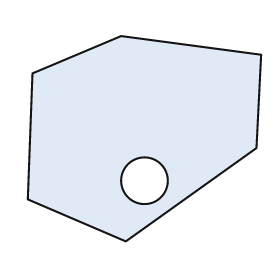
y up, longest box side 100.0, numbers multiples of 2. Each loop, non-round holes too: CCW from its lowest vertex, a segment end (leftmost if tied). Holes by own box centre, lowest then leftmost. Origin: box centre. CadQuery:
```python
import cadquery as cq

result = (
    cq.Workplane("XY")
    .moveTo(-8.0, -44.0)
    .lineTo(48.0, -4.0)
    .lineTo(50.0, 36.0)
    .lineTo(-10.0, 44.0)
    .lineTo(-48.0, 28.0)
    .lineTo(-50.0, -26.0)
    .close()
    .moveTo(0.0, -18.0)
    .circle(10.0)
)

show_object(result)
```